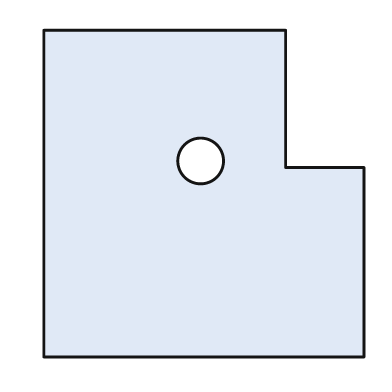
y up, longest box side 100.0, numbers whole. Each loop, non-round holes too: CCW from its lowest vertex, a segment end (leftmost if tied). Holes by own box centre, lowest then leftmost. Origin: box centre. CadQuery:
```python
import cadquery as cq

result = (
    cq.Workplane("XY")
    .moveTo(-49.0, -50.0)
    .lineTo(49.0, -50.0)
    .lineTo(49.0, 8.0)
    .lineTo(25.0, 8.0)
    .lineTo(25.0, 50.0)
    .lineTo(-49.0, 50.0)
    .close()
    .moveTo(-1.0, 10.0)
    .circle(7.0)
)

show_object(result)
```